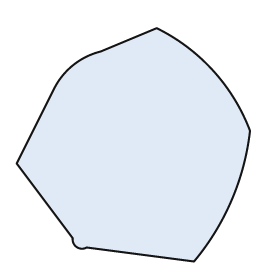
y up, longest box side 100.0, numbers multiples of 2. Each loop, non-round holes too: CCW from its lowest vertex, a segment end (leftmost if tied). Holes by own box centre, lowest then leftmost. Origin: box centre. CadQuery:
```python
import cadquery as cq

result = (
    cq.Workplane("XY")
    .moveTo(26.0, -50.0)
    .threePointArc((42.0, -24.0), (50.0, 6.0))
    .threePointArc((34.0, 32.0), (10.0, 50.0))
    .lineTo(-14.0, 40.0)
    .threePointArc((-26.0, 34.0), (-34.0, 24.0))
    .lineTo(-50.0, -8.0)
    .lineTo(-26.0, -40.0)
    .threePointArc((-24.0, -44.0), (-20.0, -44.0))
    .close()
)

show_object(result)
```